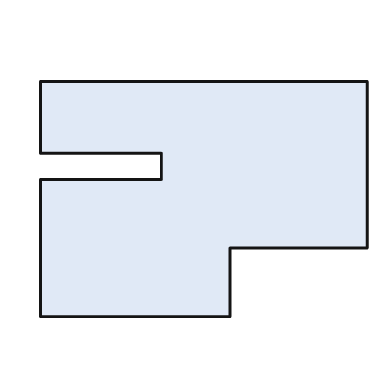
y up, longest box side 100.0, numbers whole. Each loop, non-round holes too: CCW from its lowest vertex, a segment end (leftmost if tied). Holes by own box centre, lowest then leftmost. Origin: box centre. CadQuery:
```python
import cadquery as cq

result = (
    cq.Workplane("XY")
    .moveTo(-50.0, -36.0)
    .lineTo(8.0, -36.0)
    .lineTo(8.0, -15.0)
    .lineTo(50.0, -15.0)
    .lineTo(50.0, 36.0)
    .lineTo(-50.0, 36.0)
    .lineTo(-50.0, 14.0)
    .lineTo(-13.0, 14.0)
    .lineTo(-13.0, 6.0)
    .lineTo(-50.0, 6.0)
    .close()
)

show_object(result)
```